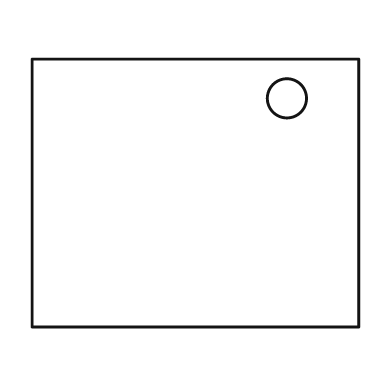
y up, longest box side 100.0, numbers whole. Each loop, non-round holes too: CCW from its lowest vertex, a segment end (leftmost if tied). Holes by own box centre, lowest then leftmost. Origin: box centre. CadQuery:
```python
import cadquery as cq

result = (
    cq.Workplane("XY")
    .moveTo(-50.0, -41.0)
    .lineTo(50.0, -41.0)
    .lineTo(50.0, 41.0)
    .lineTo(-50.0, 41.0)
    .close()
    .moveTo(28.0, 29.0)
    .circle(6.0)
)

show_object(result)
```